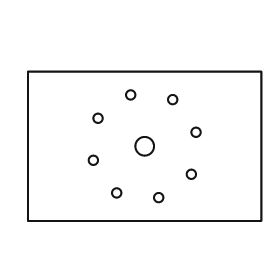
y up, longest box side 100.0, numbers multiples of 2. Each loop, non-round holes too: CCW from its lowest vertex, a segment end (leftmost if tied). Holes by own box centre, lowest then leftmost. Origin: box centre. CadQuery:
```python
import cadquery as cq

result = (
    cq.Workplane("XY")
    .moveTo(-50.0, -32.0)
    .lineTo(50.0, -32.0)
    .lineTo(50.0, 32.0)
    .lineTo(-50.0, 32.0)
    .close()
    .moveTo(6.0, -22.0)
    .circle(2.0)
    .moveTo(-12.0, -20.0)
    .circle(2.0)
    .moveTo(20.0, -12.0)
    .circle(2.0)
    .moveTo(-22.0, -6.0)
    .circle(2.0)
    .moveTo(0.0, 0.0)
    .circle(4.0)
    .moveTo(22.0, 6.0)
    .circle(2.0)
    .moveTo(-20.0, 12.0)
    .circle(2.0)
    .moveTo(12.0, 20.0)
    .circle(2.0)
    .moveTo(-6.0, 22.0)
    .circle(2.0)
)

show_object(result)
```